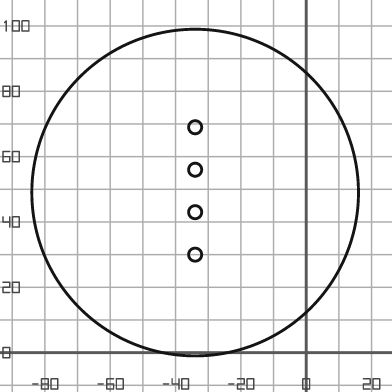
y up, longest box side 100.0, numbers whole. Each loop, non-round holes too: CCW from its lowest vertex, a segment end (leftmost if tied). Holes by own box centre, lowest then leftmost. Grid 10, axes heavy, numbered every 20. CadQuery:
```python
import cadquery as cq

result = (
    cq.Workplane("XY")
    .moveTo(-34.0, 49.0)
    .circle(50.0)
    .moveTo(-34.0, 30.0)
    .circle(2.0)
    .moveTo(-34.0, 43.0)
    .circle(2.0)
    .moveTo(-34.0, 56.0)
    .circle(2.0)
    .moveTo(-34.0, 69.0)
    .circle(2.0)
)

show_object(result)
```